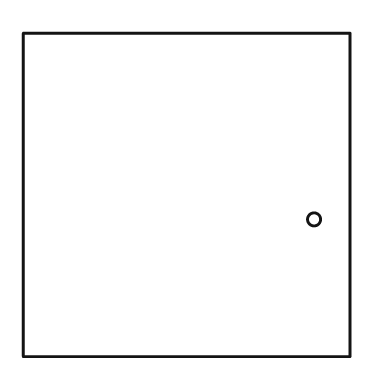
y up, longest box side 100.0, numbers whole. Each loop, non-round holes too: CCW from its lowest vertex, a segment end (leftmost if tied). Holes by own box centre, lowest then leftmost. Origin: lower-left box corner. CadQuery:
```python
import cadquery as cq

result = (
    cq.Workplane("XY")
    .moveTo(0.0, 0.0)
    .lineTo(100.0, 0.0)
    .lineTo(100.0, 99.0)
    .lineTo(0.0, 99.0)
    .close()
    .moveTo(89.0, 42.0)
    .circle(2.0)
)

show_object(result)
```